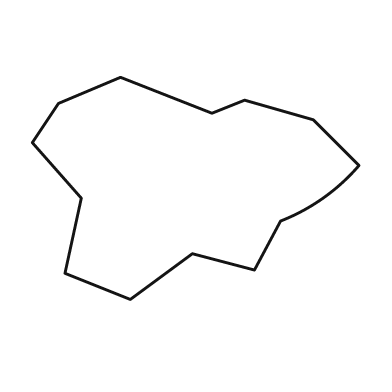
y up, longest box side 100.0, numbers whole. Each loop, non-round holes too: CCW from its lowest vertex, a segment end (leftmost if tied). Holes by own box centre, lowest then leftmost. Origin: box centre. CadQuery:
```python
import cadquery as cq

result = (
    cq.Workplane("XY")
    .moveTo(-20.0, -34.0)
    .lineTo(-1.0, -20.0)
    .lineTo(18.0, -25.0)
    .lineTo(26.0, -10.0)
    .threePointArc((39.0, -3.0), (50.0, 7.0))
    .lineTo(36.0, 21.0)
    .lineTo(15.0, 27.0)
    .lineTo(5.0, 23.0)
    .lineTo(-23.0, 34.0)
    .lineTo(-42.0, 26.0)
    .lineTo(-50.0, 14.0)
    .lineTo(-35.0, -3.0)
    .lineTo(-40.0, -26.0)
    .close()
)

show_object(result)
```